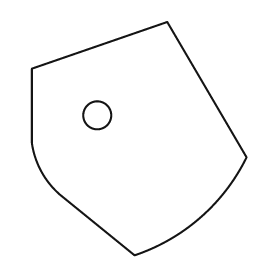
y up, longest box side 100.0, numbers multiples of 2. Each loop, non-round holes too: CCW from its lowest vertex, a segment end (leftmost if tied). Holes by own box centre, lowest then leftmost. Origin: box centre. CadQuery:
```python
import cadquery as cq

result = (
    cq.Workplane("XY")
    .moveTo(-2.0, -50.0)
    .threePointArc((26.0, -34.0), (46.0, -8.0))
    .lineTo(12.0, 50.0)
    .lineTo(-46.0, 30.0)
    .lineTo(-46.0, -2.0)
    .threePointArc((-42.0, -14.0), (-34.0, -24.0))
    .close()
    .moveTo(-18.0, 10.0)
    .circle(6.0)
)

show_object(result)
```